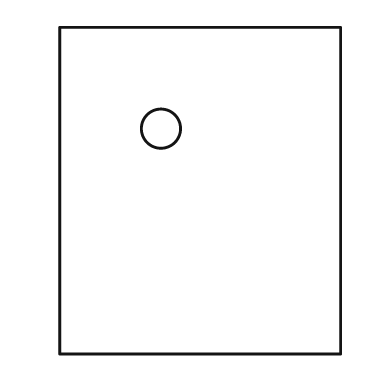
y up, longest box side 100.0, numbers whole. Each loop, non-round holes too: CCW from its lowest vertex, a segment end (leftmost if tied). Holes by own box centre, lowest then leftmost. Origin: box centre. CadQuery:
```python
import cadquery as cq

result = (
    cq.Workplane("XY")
    .moveTo(-43.0, -50.0)
    .lineTo(43.0, -50.0)
    .lineTo(43.0, 50.0)
    .lineTo(-43.0, 50.0)
    .close()
    .moveTo(-12.0, 19.0)
    .circle(6.0)
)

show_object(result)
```